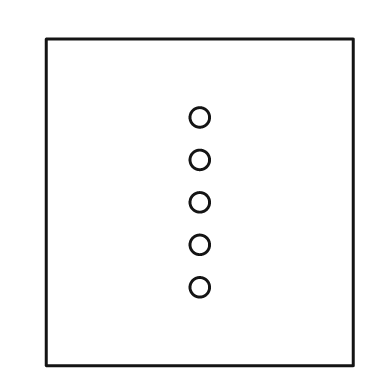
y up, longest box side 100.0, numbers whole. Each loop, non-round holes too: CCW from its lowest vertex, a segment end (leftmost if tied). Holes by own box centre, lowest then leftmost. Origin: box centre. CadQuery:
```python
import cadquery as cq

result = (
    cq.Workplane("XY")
    .moveTo(-47.0, -50.0)
    .lineTo(47.0, -50.0)
    .lineTo(47.0, 50.0)
    .lineTo(-47.0, 50.0)
    .close()
    .moveTo(0.0, -26.0)
    .circle(3.0)
    .moveTo(0.0, -13.0)
    .circle(3.0)
    .moveTo(0.0, 0.0)
    .circle(3.0)
    .moveTo(0.0, 13.0)
    .circle(3.0)
    .moveTo(0.0, 26.0)
    .circle(3.0)
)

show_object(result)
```